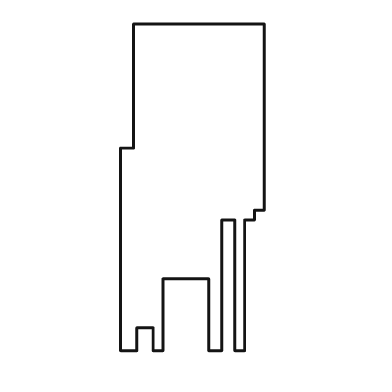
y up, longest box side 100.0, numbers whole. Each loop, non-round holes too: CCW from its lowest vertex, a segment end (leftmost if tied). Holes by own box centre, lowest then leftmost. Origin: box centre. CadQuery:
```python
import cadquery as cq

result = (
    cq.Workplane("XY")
    .moveTo(-22.0, -50.0)
    .lineTo(-17.0, -50.0)
    .lineTo(-17.0, -43.0)
    .lineTo(-12.0, -43.0)
    .lineTo(-12.0, -50.0)
    .lineTo(-9.0, -50.0)
    .lineTo(-9.0, -28.0)
    .lineTo(5.0, -28.0)
    .lineTo(5.0, -50.0)
    .lineTo(9.0, -50.0)
    .lineTo(9.0, -10.0)
    .lineTo(13.0, -10.0)
    .lineTo(13.0, -50.0)
    .lineTo(16.0, -50.0)
    .lineTo(16.0, -10.0)
    .lineTo(19.0, -10.0)
    .lineTo(19.0, -7.0)
    .lineTo(22.0, -7.0)
    .lineTo(22.0, 50.0)
    .lineTo(-18.0, 50.0)
    .lineTo(-18.0, 12.0)
    .lineTo(-22.0, 12.0)
    .close()
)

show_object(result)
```